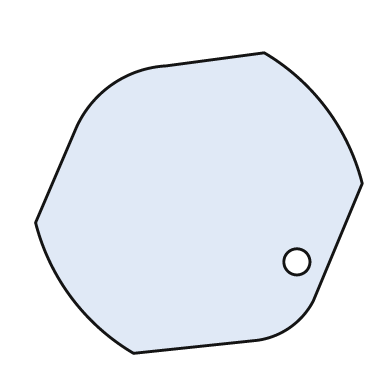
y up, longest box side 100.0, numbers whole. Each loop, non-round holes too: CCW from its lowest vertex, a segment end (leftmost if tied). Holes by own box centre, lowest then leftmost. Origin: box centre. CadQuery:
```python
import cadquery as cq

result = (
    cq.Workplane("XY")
    .moveTo(-20.0, -46.0)
    .lineTo(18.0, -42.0)
    .threePointArc((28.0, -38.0), (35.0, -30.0))
    .lineTo(50.0, 6.0)
    .threePointArc((39.0, 29.0), (20.0, 46.0))
    .lineTo(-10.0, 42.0)
    .threePointArc((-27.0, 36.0), (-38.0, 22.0))
    .lineTo(-50.0, -6.0)
    .threePointArc((-39.0, -29.0), (-20.0, -46.0))
    .close()
    .moveTo(30.0, -18.0)
    .circle(4.0)
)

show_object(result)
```